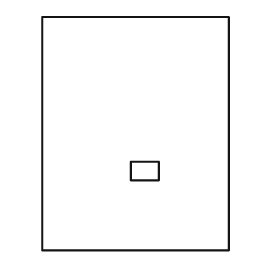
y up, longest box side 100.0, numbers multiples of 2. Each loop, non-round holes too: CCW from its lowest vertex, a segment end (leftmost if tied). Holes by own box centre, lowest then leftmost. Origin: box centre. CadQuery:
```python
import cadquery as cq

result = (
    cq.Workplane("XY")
    .moveTo(-40.0, -50.0)
    .lineTo(40.0, -50.0)
    .lineTo(40.0, 50.0)
    .lineTo(-40.0, 50.0)
    .close()
    .moveTo(-2.0, -20.0)
    .lineTo(10.0, -20.0)
    .lineTo(10.0, -12.0)
    .lineTo(-2.0, -12.0)
    .close()
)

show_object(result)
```